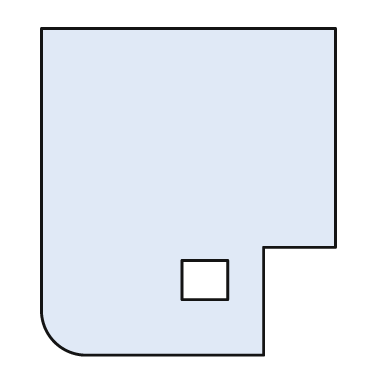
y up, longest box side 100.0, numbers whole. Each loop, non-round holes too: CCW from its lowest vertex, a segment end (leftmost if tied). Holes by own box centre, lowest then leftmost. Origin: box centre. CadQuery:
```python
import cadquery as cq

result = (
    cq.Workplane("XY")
    .moveTo(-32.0, -50.0)
    .lineTo(23.0, -50.0)
    .lineTo(23.0, -17.0)
    .lineTo(45.0, -17.0)
    .lineTo(45.0, 50.0)
    .lineTo(-45.0, 50.0)
    .lineTo(-45.0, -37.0)
    .threePointArc((-41.0, -46.0), (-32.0, -50.0))
    .close()
    .moveTo(-2.0, -33.0)
    .lineTo(12.0, -33.0)
    .lineTo(12.0, -21.0)
    .lineTo(-2.0, -21.0)
    .close()
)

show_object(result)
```